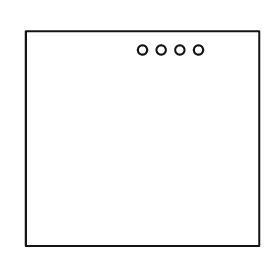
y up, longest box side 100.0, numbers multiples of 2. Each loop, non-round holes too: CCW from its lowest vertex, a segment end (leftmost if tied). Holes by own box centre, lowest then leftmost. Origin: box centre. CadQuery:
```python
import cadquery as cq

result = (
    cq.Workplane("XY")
    .moveTo(-50.0, -46.0)
    .lineTo(50.0, -46.0)
    .lineTo(50.0, 46.0)
    .lineTo(-50.0, 46.0)
    .close()
    .moveTo(0.0, 38.0)
    .circle(2.0)
    .moveTo(8.0, 38.0)
    .circle(2.0)
    .moveTo(16.0, 38.0)
    .circle(2.0)
    .moveTo(24.0, 38.0)
    .circle(2.0)
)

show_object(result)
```